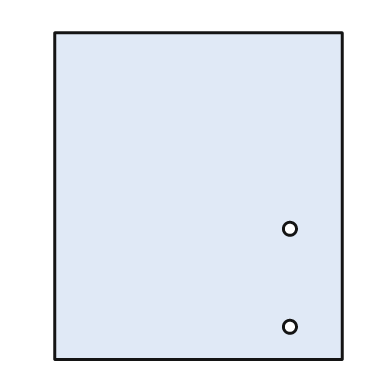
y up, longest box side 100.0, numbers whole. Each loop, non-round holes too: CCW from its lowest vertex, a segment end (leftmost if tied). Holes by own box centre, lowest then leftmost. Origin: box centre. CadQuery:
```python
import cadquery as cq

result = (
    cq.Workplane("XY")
    .moveTo(-44.0, -50.0)
    .lineTo(44.0, -50.0)
    .lineTo(44.0, 50.0)
    .lineTo(-44.0, 50.0)
    .close()
    .moveTo(28.0, -40.0)
    .circle(2.0)
    .moveTo(28.0, -10.0)
    .circle(2.0)
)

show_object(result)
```